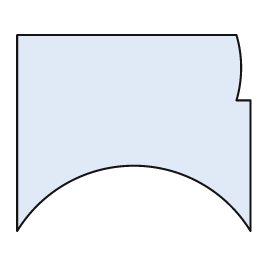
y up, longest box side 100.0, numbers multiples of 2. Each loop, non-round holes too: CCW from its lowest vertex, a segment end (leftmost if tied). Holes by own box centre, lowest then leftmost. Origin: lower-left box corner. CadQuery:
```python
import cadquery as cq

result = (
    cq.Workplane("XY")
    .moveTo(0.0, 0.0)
    .threePointArc((50.0, 28.0), (100.0, 0.0))
    .lineTo(100.0, 56.0)
    .lineTo(94.0, 56.0)
    .threePointArc((96.0, 70.0), (94.0, 84.0))
    .lineTo(0.0, 84.0)
    .close()
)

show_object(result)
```